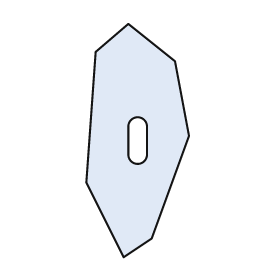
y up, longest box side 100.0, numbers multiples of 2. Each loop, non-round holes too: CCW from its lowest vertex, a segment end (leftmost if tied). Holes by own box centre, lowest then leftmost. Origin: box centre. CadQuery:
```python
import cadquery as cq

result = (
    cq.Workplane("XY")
    .moveTo(-6.0, -50.0)
    .lineTo(6.0, -42.0)
    .lineTo(22.0, 2.0)
    .lineTo(16.0, 34.0)
    .lineTo(-4.0, 50.0)
    .lineTo(-18.0, 38.0)
    .lineTo(-22.0, -18.0)
    .close()
    .moveTo(-4.0, -6.0)
    .threePointArc((0.0, -10.0), (4.0, -6.0))
    .lineTo(4.0, 6.0)
    .threePointArc((0.0, 10.0), (-4.0, 6.0))
    .close()
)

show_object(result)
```